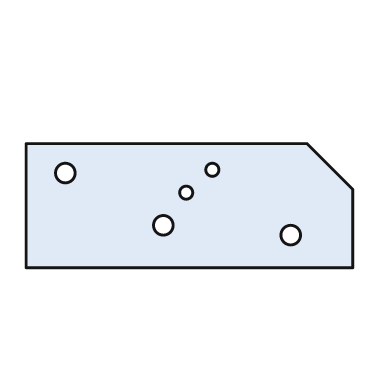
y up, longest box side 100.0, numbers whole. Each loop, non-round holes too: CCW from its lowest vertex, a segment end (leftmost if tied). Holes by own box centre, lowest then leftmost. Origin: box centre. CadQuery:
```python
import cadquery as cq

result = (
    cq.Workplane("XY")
    .moveTo(-50.0, -19.0)
    .lineTo(50.0, -19.0)
    .lineTo(50.0, 5.0)
    .lineTo(36.0, 19.0)
    .lineTo(-50.0, 19.0)
    .close()
    .moveTo(31.0, -9.0)
    .circle(3.0)
    .moveTo(-8.0, -6.0)
    .circle(3.0)
    .moveTo(-1.0, 4.0)
    .circle(2.0)
    .moveTo(-38.0, 10.0)
    .circle(3.0)
    .moveTo(7.0, 11.0)
    .circle(2.0)
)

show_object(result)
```